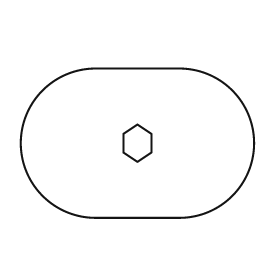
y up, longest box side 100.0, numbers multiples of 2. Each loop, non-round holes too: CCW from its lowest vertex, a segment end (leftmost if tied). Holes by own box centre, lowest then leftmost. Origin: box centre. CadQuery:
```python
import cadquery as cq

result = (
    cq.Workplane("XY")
    .moveTo(-18.0, -32.0)
    .lineTo(18.0, -32.0)
    .threePointArc((50.0, 0.0), (18.0, 32.0))
    .lineTo(-18.0, 32.0)
    .threePointArc((-50.0, 0.0), (-18.0, -32.0))
    .close()
    .moveTo(0.0, -8.0)
    .lineTo(6.0, -4.0)
    .lineTo(6.0, 4.0)
    .lineTo(0.0, 8.0)
    .lineTo(-6.0, 4.0)
    .lineTo(-6.0, -4.0)
    .close()
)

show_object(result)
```